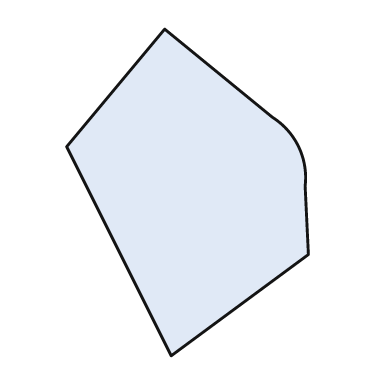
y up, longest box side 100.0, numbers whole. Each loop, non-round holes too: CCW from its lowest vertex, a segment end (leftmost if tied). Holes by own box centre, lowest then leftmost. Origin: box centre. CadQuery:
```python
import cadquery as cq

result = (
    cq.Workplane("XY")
    .moveTo(-5.0, -50.0)
    .lineTo(37.0, -19.0)
    .lineTo(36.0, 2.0)
    .threePointArc((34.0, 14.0), (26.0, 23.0))
    .lineTo(-7.0, 50.0)
    .lineTo(-37.0, 14.0)
    .close()
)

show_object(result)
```